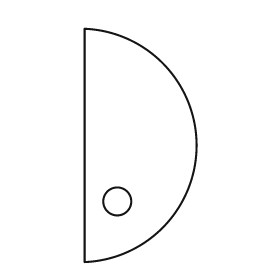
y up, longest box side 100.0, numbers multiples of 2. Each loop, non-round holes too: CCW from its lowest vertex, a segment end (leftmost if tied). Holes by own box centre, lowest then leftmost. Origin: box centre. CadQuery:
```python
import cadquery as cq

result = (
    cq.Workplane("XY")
    .moveTo(-24.0, -50.0)
    .threePointArc((24.0, 0.0), (-24.0, 50.0))
    .close()
    .moveTo(-10.0, -24.0)
    .circle(6.0)
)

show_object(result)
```